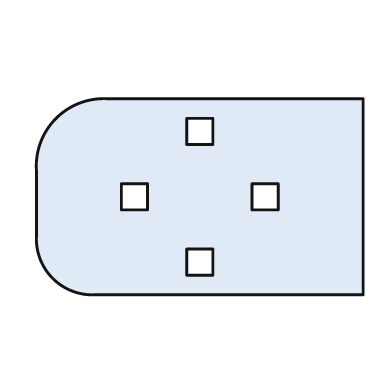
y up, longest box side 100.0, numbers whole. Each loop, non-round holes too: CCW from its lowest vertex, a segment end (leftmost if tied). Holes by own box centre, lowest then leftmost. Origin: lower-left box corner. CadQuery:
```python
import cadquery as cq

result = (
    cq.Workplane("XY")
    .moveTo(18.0, 0.0)
    .lineTo(100.0, 0.0)
    .lineTo(100.0, 60.0)
    .lineTo(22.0, 60.0)
    .threePointArc((6.0, 54.0), (0.0, 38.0))
    .lineTo(0.0, 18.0)
    .threePointArc((5.0, 5.0), (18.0, 0.0))
    .close()
    .moveTo(46.0, 6.0)
    .lineTo(54.0, 6.0)
    .lineTo(54.0, 14.0)
    .lineTo(46.0, 14.0)
    .close()
    .moveTo(26.0, 26.0)
    .lineTo(34.0, 26.0)
    .lineTo(34.0, 34.0)
    .lineTo(26.0, 34.0)
    .close()
    .moveTo(66.0, 26.0)
    .lineTo(74.0, 26.0)
    .lineTo(74.0, 34.0)
    .lineTo(66.0, 34.0)
    .close()
    .moveTo(46.0, 46.0)
    .lineTo(54.0, 46.0)
    .lineTo(54.0, 54.0)
    .lineTo(46.0, 54.0)
    .close()
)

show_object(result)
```